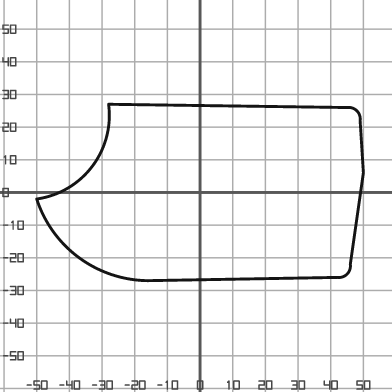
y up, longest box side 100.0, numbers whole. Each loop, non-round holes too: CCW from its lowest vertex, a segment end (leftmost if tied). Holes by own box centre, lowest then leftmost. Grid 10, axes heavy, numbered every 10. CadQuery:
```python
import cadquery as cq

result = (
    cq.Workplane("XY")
    .moveTo(-16.0, -27.0)
    .lineTo(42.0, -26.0)
    .threePointArc((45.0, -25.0), (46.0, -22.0))
    .lineTo(50.0, 6.0)
    .lineTo(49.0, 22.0)
    .threePointArc((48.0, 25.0), (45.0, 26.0))
    .lineTo(-28.0, 27.0)
    .threePointArc((-33.0, 8.0), (-50.0, -2.0))
    .threePointArc((-37.0, -20.0), (-16.0, -27.0))
    .close()
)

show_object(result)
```